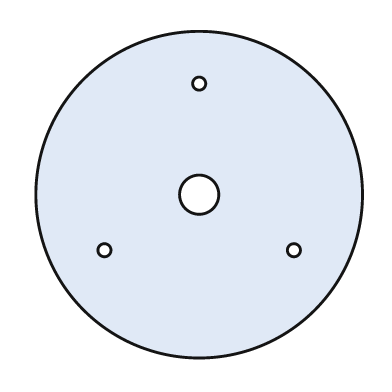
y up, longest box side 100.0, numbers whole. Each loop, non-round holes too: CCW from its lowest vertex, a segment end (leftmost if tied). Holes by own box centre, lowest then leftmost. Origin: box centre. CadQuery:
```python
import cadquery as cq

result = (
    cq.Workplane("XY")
    .moveTo(0.0, 0.0)
    .circle(50.0)
    .moveTo(-29.0, -17.0)
    .circle(2.0)
    .moveTo(29.0, -17.0)
    .circle(2.0)
    .moveTo(0.0, 0.0)
    .circle(6.0)
    .moveTo(0.0, 34.0)
    .circle(2.0)
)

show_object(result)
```